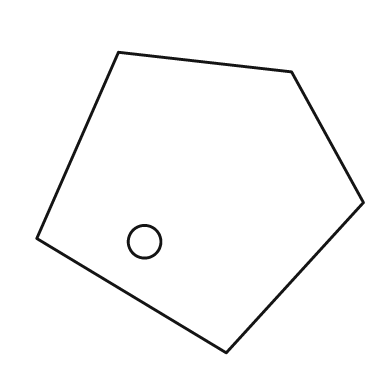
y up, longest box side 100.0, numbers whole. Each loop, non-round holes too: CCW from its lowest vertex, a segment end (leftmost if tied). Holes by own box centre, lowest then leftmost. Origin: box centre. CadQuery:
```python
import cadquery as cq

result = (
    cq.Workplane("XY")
    .moveTo(8.0, -46.0)
    .lineTo(50.0, 0.0)
    .lineTo(28.0, 40.0)
    .lineTo(-25.0, 46.0)
    .lineTo(-50.0, -11.0)
    .close()
    .moveTo(-17.0, -12.0)
    .circle(5.0)
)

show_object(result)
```